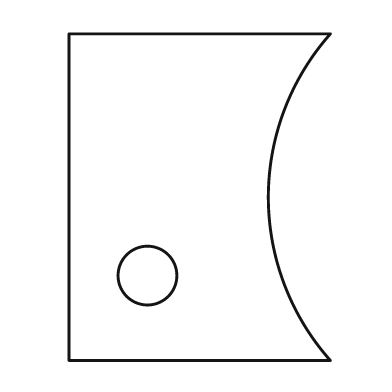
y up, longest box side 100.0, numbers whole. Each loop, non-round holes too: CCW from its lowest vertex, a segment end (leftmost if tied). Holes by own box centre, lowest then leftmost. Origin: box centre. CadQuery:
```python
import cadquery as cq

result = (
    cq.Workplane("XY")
    .moveTo(-40.0, -50.0)
    .lineTo(40.0, -50.0)
    .threePointArc((21.0, 0.0), (40.0, 50.0))
    .lineTo(-40.0, 50.0)
    .close()
    .moveTo(-16.0, -24.0)
    .circle(9.0)
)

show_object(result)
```